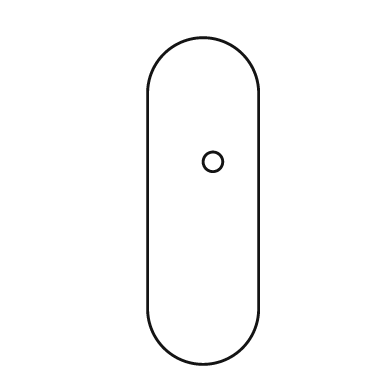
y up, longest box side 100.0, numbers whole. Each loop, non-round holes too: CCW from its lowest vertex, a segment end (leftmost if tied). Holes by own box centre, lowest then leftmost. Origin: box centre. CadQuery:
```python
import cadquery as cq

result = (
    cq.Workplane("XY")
    .moveTo(-17.0, -33.0)
    .threePointArc((0.0, -50.0), (17.0, -33.0))
    .lineTo(17.0, 33.0)
    .threePointArc((0.0, 50.0), (-17.0, 33.0))
    .close()
    .moveTo(3.0, 12.0)
    .circle(3.0)
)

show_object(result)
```